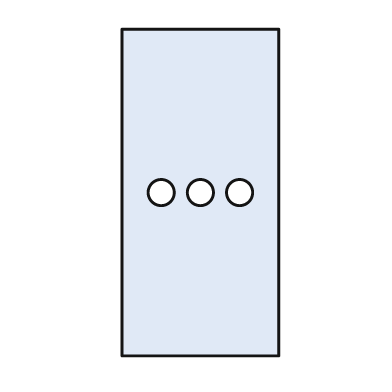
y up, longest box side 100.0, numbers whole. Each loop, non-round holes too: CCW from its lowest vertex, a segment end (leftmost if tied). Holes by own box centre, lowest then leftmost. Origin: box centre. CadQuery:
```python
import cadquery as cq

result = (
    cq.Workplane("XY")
    .moveTo(-24.0, -50.0)
    .lineTo(24.0, -50.0)
    .lineTo(24.0, 50.0)
    .lineTo(-24.0, 50.0)
    .close()
    .moveTo(-12.0, 0.0)
    .circle(4.0)
    .moveTo(0.0, 0.0)
    .circle(4.0)
    .moveTo(12.0, 0.0)
    .circle(4.0)
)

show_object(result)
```